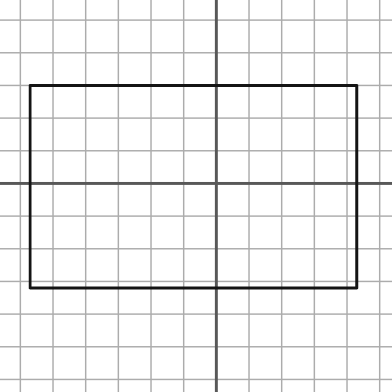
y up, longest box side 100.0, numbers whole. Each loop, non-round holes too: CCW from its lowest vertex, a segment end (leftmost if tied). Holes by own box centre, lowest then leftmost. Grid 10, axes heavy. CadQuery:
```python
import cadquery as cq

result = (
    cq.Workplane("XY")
    .moveTo(-57.0, -32.0)
    .lineTo(43.0, -32.0)
    .lineTo(43.0, 30.0)
    .lineTo(-57.0, 30.0)
    .close()
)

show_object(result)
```